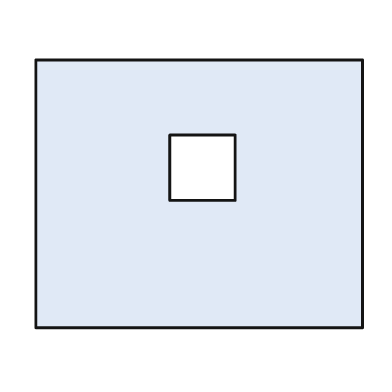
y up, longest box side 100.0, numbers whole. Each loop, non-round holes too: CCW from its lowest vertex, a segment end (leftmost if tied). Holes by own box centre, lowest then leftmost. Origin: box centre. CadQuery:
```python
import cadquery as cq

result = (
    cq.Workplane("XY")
    .moveTo(-50.0, -41.0)
    .lineTo(50.0, -41.0)
    .lineTo(50.0, 41.0)
    .lineTo(-50.0, 41.0)
    .close()
    .moveTo(-9.0, -2.0)
    .lineTo(11.0, -2.0)
    .lineTo(11.0, 18.0)
    .lineTo(-9.0, 18.0)
    .close()
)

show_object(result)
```